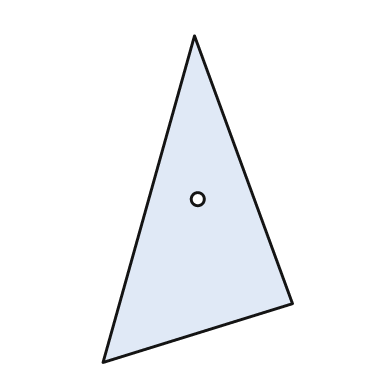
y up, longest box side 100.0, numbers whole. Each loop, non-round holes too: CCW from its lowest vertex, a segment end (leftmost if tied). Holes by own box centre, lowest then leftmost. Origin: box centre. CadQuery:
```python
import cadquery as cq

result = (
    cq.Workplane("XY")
    .moveTo(-29.0, -50.0)
    .lineTo(29.0, -32.0)
    .lineTo(-1.0, 50.0)
    .close()
    .moveTo(0.0, 0.0)
    .circle(2.0)
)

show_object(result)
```